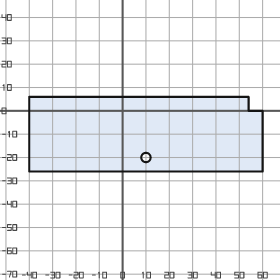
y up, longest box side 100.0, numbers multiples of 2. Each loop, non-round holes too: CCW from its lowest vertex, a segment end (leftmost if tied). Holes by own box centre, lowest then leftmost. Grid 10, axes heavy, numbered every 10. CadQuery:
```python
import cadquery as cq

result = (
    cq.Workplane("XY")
    .moveTo(-40.0, -26.0)
    .lineTo(60.0, -26.0)
    .lineTo(60.0, 0.0)
    .lineTo(54.0, 0.0)
    .lineTo(54.0, 6.0)
    .lineTo(-40.0, 6.0)
    .close()
    .moveTo(10.0, -20.0)
    .circle(2.0)
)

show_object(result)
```